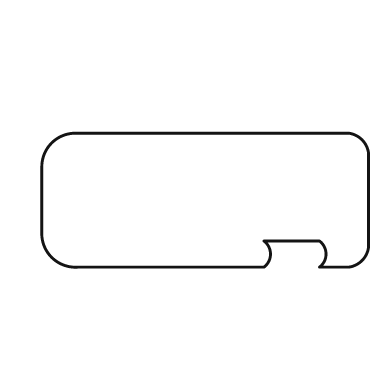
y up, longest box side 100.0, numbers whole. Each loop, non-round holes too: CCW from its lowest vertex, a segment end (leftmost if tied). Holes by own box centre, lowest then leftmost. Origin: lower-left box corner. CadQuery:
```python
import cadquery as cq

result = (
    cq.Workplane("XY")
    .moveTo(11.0, 0.0)
    .lineTo(68.0, 0.0)
    .threePointArc((70.0, 4.0), (68.0, 8.0))
    .lineTo(85.0, 8.0)
    .threePointArc((87.0, 4.0), (85.0, 0.0))
    .lineTo(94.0, 0.0)
    .threePointArc((98.0, 2.0), (100.0, 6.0))
    .lineTo(100.0, 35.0)
    .threePointArc((98.0, 39.0), (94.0, 41.0))
    .lineTo(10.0, 41.0)
    .threePointArc((3.0, 38.0), (0.0, 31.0))
    .lineTo(0.0, 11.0)
    .threePointArc((3.0, 3.0), (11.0, 0.0))
    .close()
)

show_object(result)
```